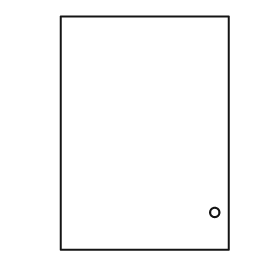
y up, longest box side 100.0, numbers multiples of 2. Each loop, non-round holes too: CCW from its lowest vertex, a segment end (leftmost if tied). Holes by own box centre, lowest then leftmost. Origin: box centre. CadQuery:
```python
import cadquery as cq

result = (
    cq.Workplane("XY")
    .moveTo(-36.0, -50.0)
    .lineTo(36.0, -50.0)
    .lineTo(36.0, 50.0)
    .lineTo(-36.0, 50.0)
    .close()
    .moveTo(30.0, -34.0)
    .circle(2.0)
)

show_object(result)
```